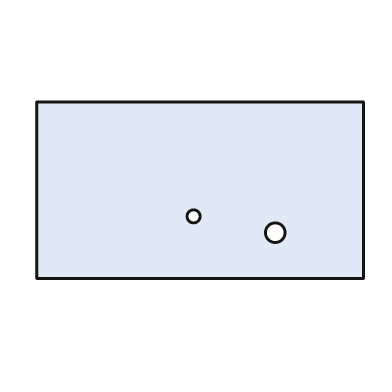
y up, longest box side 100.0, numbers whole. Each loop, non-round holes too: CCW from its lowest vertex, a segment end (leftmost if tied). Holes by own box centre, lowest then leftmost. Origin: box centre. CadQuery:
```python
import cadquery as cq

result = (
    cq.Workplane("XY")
    .moveTo(-50.0, -27.0)
    .lineTo(50.0, -27.0)
    .lineTo(50.0, 27.0)
    .lineTo(-50.0, 27.0)
    .close()
    .moveTo(23.0, -13.0)
    .circle(3.0)
    .moveTo(-2.0, -8.0)
    .circle(2.0)
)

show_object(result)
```